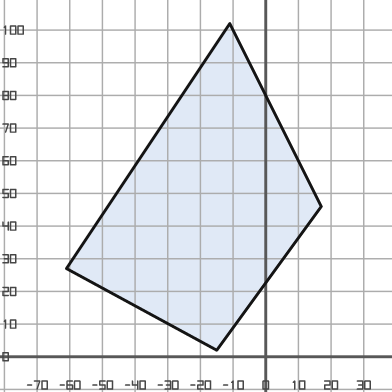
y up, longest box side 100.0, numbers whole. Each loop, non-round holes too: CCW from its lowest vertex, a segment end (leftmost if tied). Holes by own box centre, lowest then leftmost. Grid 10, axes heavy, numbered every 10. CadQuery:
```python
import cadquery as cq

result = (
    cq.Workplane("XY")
    .moveTo(-15.0, 2.0)
    .lineTo(17.0, 46.0)
    .lineTo(-11.0, 102.0)
    .lineTo(-61.0, 27.0)
    .close()
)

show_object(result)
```